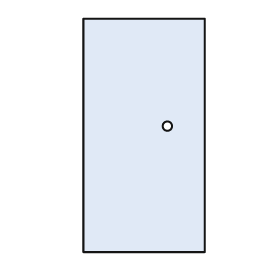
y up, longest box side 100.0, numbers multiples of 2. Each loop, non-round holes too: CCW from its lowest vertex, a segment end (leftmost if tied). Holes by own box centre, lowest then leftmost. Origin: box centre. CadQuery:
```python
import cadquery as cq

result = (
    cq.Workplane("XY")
    .moveTo(-26.0, -50.0)
    .lineTo(26.0, -50.0)
    .lineTo(26.0, 50.0)
    .lineTo(-26.0, 50.0)
    .close()
    .moveTo(10.0, 4.0)
    .circle(2.0)
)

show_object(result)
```